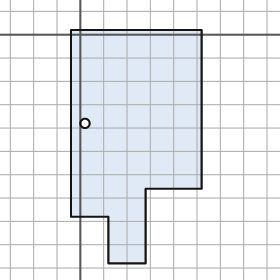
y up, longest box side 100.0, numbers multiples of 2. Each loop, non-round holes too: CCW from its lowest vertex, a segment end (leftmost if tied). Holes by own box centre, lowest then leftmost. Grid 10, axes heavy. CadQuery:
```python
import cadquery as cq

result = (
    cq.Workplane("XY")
    .moveTo(12.0, -98.0)
    .lineTo(28.0, -98.0)
    .lineTo(28.0, -66.0)
    .lineTo(52.0, -66.0)
    .lineTo(52.0, 2.0)
    .lineTo(-4.0, 2.0)
    .lineTo(-4.0, -78.0)
    .lineTo(12.0, -78.0)
    .close()
    .moveTo(2.0, -38.0)
    .circle(2.0)
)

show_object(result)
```